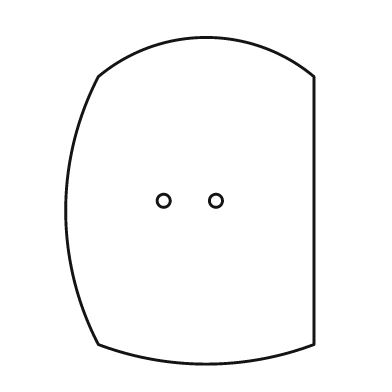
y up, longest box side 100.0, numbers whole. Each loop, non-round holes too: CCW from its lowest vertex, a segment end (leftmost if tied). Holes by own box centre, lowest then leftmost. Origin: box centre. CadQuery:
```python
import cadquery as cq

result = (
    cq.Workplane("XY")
    .moveTo(-28.0, -44.0)
    .threePointArc((5.0, -50.0), (38.0, -44.0))
    .lineTo(38.0, 38.0)
    .threePointArc((5.0, 50.0), (-28.0, 38.0))
    .threePointArc((-38.0, -3.0), (-28.0, -44.0))
    .close()
    .moveTo(-8.0, 0.0)
    .circle(2.0)
    .moveTo(8.0, 0.0)
    .circle(2.0)
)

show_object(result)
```